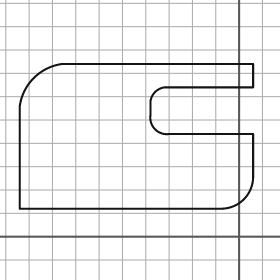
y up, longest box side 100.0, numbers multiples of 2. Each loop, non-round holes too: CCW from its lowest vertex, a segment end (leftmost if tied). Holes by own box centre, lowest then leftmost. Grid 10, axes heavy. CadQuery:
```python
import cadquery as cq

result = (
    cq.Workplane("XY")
    .moveTo(-94.0, 12.0)
    .lineTo(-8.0, 12.0)
    .threePointArc((2.0, 16.0), (6.0, 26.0))
    .lineTo(6.0, 44.0)
    .lineTo(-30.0, 44.0)
    .threePointArc((-36.0, 46.0), (-38.0, 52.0))
    .lineTo(-38.0, 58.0)
    .threePointArc((-36.0, 62.0), (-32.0, 64.0))
    .lineTo(6.0, 64.0)
    .lineTo(6.0, 74.0)
    .lineTo(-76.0, 74.0)
    .threePointArc((-88.0, 68.0), (-94.0, 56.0))
    .close()
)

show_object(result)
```